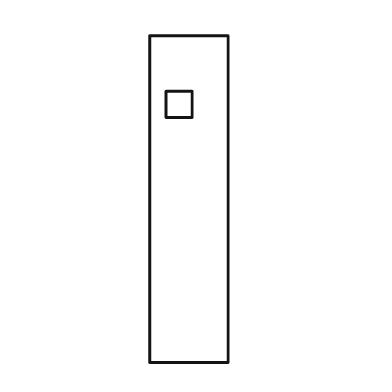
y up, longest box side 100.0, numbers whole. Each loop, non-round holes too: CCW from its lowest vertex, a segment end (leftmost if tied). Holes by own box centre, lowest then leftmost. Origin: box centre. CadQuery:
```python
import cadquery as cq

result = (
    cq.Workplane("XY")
    .moveTo(-12.0, -50.0)
    .lineTo(12.0, -50.0)
    .lineTo(12.0, 50.0)
    .lineTo(-12.0, 50.0)
    .close()
    .moveTo(-7.0, 25.0)
    .lineTo(1.0, 25.0)
    .lineTo(1.0, 33.0)
    .lineTo(-7.0, 33.0)
    .close()
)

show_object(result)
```